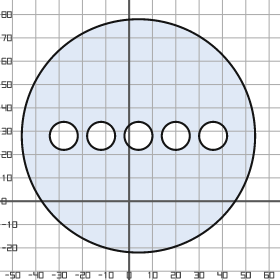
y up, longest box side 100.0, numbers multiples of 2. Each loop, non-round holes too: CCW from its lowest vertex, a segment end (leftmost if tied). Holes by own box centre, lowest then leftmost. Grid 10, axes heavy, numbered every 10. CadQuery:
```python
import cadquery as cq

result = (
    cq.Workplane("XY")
    .moveTo(4.0, 28.0)
    .circle(50.0)
    .moveTo(-28.0, 28.0)
    .circle(6.0)
    .moveTo(-12.0, 28.0)
    .circle(6.0)
    .moveTo(4.0, 28.0)
    .circle(6.0)
    .moveTo(20.0, 28.0)
    .circle(6.0)
    .moveTo(36.0, 28.0)
    .circle(6.0)
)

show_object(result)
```